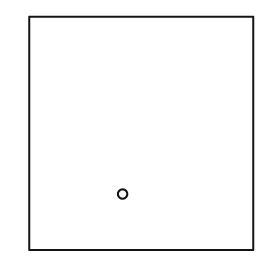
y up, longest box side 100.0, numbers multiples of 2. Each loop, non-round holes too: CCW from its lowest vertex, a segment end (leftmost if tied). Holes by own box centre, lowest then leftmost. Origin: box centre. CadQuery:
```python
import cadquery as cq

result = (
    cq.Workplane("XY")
    .moveTo(-48.0, -50.0)
    .lineTo(48.0, -50.0)
    .lineTo(48.0, 50.0)
    .lineTo(-48.0, 50.0)
    .close()
    .moveTo(-8.0, -26.0)
    .circle(2.0)
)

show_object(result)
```